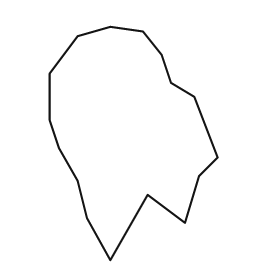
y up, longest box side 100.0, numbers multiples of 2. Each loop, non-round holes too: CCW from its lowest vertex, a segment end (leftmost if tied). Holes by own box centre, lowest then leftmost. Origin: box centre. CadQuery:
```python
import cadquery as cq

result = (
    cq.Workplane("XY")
    .moveTo(-10.0, -50.0)
    .lineTo(6.0, -22.0)
    .lineTo(22.0, -34.0)
    .lineTo(28.0, -14.0)
    .lineTo(36.0, -6.0)
    .lineTo(26.0, 20.0)
    .lineTo(16.0, 26.0)
    .lineTo(12.0, 38.0)
    .lineTo(4.0, 48.0)
    .lineTo(-10.0, 50.0)
    .lineTo(-24.0, 46.0)
    .lineTo(-36.0, 30.0)
    .lineTo(-36.0, 10.0)
    .lineTo(-32.0, -2.0)
    .lineTo(-24.0, -16.0)
    .lineTo(-20.0, -32.0)
    .close()
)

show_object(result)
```